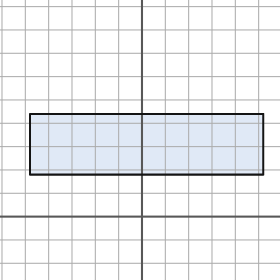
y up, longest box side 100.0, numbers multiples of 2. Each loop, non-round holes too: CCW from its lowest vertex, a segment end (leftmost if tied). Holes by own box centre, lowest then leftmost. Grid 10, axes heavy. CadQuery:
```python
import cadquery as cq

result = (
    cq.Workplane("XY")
    .moveTo(-48.0, 18.0)
    .lineTo(52.0, 18.0)
    .lineTo(52.0, 44.0)
    .lineTo(-48.0, 44.0)
    .close()
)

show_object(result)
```